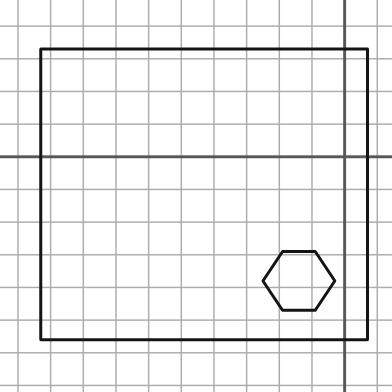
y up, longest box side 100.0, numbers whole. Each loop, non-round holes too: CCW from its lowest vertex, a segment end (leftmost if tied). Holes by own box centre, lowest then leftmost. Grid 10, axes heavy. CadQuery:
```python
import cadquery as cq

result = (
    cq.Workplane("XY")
    .moveTo(-93.0, -56.0)
    .lineTo(7.0, -56.0)
    .lineTo(7.0, 33.0)
    .lineTo(-93.0, 33.0)
    .close()
    .moveTo(-19.0, -47.0)
    .lineTo(-9.0, -47.0)
    .lineTo(-3.0, -38.0)
    .lineTo(-9.0, -29.0)
    .lineTo(-19.0, -29.0)
    .lineTo(-25.0, -38.0)
    .close()
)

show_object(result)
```